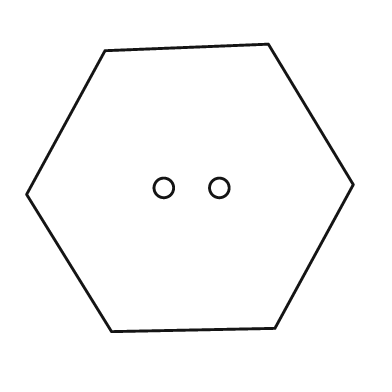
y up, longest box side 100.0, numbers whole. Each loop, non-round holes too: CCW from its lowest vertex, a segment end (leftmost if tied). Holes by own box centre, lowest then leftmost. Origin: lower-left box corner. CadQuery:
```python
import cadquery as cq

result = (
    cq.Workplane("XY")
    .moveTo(26.0, 0.0)
    .lineTo(76.0, 1.0)
    .lineTo(100.0, 45.0)
    .lineTo(74.0, 88.0)
    .lineTo(24.0, 86.0)
    .lineTo(0.0, 42.0)
    .close()
    .moveTo(42.0, 44.0)
    .circle(3.0)
    .moveTo(59.0, 44.0)
    .circle(3.0)
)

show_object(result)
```